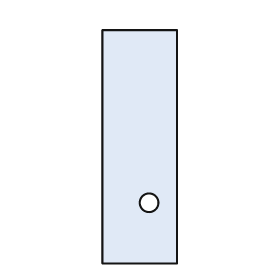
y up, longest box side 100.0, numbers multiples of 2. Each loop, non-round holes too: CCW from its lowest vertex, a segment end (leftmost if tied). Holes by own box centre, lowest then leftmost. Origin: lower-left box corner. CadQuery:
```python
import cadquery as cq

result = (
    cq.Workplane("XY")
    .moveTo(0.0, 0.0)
    .lineTo(32.0, 0.0)
    .lineTo(32.0, 100.0)
    .lineTo(0.0, 100.0)
    .close()
    .moveTo(20.0, 26.0)
    .circle(4.0)
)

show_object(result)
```